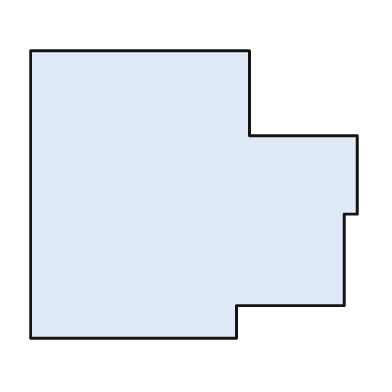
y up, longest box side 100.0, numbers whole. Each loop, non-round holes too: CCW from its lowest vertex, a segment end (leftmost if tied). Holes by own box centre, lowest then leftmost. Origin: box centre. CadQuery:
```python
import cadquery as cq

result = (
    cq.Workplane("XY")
    .moveTo(-50.0, -44.0)
    .lineTo(13.0, -44.0)
    .lineTo(13.0, -34.0)
    .lineTo(46.0, -34.0)
    .lineTo(46.0, -6.0)
    .lineTo(50.0, -6.0)
    .lineTo(50.0, 18.0)
    .lineTo(17.0, 18.0)
    .lineTo(17.0, 44.0)
    .lineTo(-50.0, 44.0)
    .close()
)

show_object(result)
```